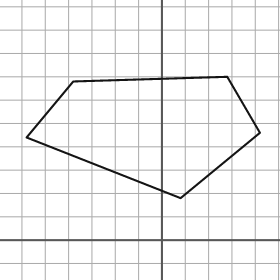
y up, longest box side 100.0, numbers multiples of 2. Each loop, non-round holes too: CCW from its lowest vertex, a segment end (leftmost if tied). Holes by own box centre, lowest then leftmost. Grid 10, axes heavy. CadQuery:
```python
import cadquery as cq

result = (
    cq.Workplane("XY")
    .moveTo(8.0, 18.0)
    .lineTo(42.0, 46.0)
    .lineTo(28.0, 70.0)
    .lineTo(-38.0, 68.0)
    .lineTo(-58.0, 44.0)
    .close()
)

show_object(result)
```